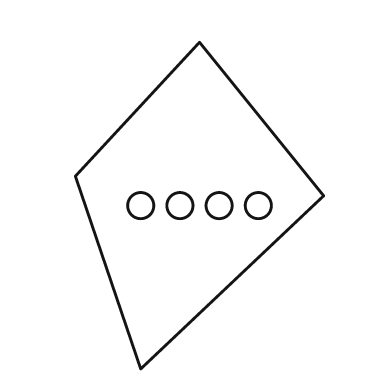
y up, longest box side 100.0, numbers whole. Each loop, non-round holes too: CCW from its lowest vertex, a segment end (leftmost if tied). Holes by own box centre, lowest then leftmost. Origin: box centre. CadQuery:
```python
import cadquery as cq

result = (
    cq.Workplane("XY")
    .moveTo(-18.0, -50.0)
    .lineTo(38.0, 3.0)
    .lineTo(0.0, 50.0)
    .lineTo(-38.0, 9.0)
    .close()
    .moveTo(-18.0, 0.0)
    .circle(4.0)
    .moveTo(-6.0, 0.0)
    .circle(4.0)
    .moveTo(6.0, 0.0)
    .circle(4.0)
    .moveTo(18.0, 0.0)
    .circle(4.0)
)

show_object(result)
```